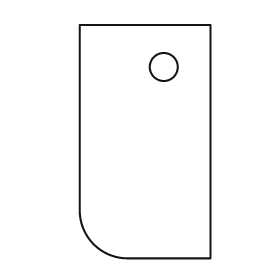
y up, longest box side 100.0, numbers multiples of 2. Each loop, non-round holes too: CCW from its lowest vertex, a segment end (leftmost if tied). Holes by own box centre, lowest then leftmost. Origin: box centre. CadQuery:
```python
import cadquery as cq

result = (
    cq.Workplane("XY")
    .moveTo(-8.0, -50.0)
    .lineTo(28.0, -50.0)
    .lineTo(28.0, 50.0)
    .lineTo(-28.0, 50.0)
    .lineTo(-28.0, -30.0)
    .threePointArc((-22.0, -44.0), (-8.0, -50.0))
    .close()
    .moveTo(8.0, 32.0)
    .circle(6.0)
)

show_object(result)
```